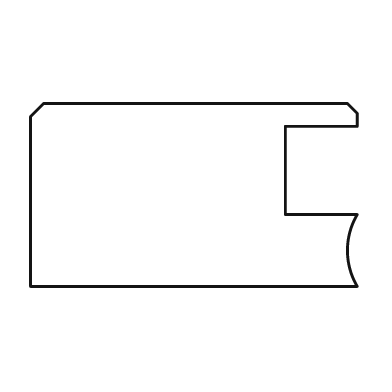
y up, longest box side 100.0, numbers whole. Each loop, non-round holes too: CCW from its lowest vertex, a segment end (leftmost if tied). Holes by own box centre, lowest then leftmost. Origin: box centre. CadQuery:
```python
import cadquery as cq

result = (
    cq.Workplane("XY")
    .moveTo(-50.0, -28.0)
    .lineTo(50.0, -28.0)
    .threePointArc((47.0, -17.0), (50.0, -6.0))
    .lineTo(28.0, -6.0)
    .lineTo(28.0, 21.0)
    .lineTo(50.0, 21.0)
    .lineTo(50.0, 25.0)
    .lineTo(47.0, 28.0)
    .lineTo(-46.0, 28.0)
    .lineTo(-50.0, 24.0)
    .close()
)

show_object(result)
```